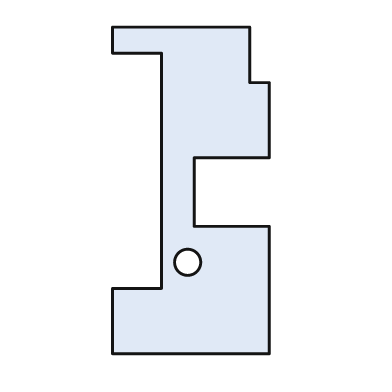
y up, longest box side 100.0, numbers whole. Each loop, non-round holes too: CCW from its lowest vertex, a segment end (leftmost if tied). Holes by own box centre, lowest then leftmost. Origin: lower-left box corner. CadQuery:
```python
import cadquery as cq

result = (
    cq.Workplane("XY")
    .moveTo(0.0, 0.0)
    .lineTo(48.0, 0.0)
    .lineTo(48.0, 39.0)
    .lineTo(25.0, 39.0)
    .lineTo(25.0, 60.0)
    .lineTo(48.0, 60.0)
    .lineTo(48.0, 83.0)
    .lineTo(42.0, 83.0)
    .lineTo(42.0, 100.0)
    .lineTo(0.0, 100.0)
    .lineTo(0.0, 92.0)
    .lineTo(15.0, 92.0)
    .lineTo(15.0, 20.0)
    .lineTo(0.0, 20.0)
    .close()
    .moveTo(23.0, 28.0)
    .circle(4.0)
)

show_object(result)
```